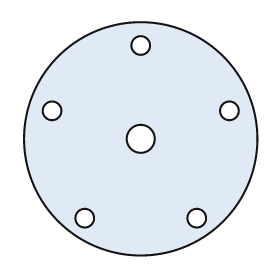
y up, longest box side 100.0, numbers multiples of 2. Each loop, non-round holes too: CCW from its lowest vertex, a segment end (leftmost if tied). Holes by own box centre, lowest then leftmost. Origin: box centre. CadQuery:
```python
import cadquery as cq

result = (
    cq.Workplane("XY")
    .moveTo(0.0, 0.0)
    .circle(50.0)
    .moveTo(-24.0, -34.0)
    .circle(4.0)
    .moveTo(24.0, -34.0)
    .circle(4.0)
    .moveTo(0.0, 0.0)
    .circle(6.0)
    .moveTo(-38.0, 12.0)
    .circle(4.0)
    .moveTo(38.0, 12.0)
    .circle(4.0)
    .moveTo(0.0, 40.0)
    .circle(4.0)
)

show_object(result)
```